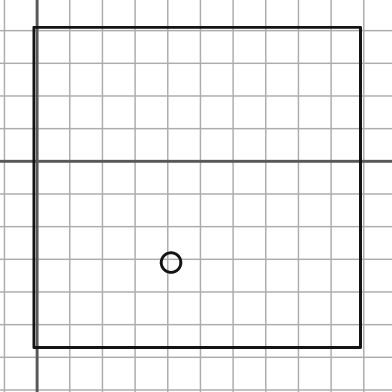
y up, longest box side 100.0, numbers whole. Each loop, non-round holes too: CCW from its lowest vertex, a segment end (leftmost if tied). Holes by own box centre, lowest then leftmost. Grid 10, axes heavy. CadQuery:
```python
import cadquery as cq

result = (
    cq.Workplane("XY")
    .moveTo(-1.0, -57.0)
    .lineTo(99.0, -57.0)
    .lineTo(99.0, 41.0)
    .lineTo(-1.0, 41.0)
    .close()
    .moveTo(41.0, -31.0)
    .circle(3.0)
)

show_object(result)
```